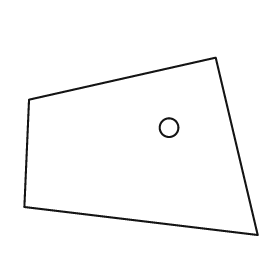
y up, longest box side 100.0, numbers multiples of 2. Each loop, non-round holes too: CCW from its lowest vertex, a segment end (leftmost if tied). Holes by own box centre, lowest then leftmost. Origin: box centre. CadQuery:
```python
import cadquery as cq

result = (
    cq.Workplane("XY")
    .moveTo(50.0, -38.0)
    .lineTo(32.0, 38.0)
    .lineTo(-48.0, 20.0)
    .lineTo(-50.0, -26.0)
    .close()
    .moveTo(12.0, 8.0)
    .circle(4.0)
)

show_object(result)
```